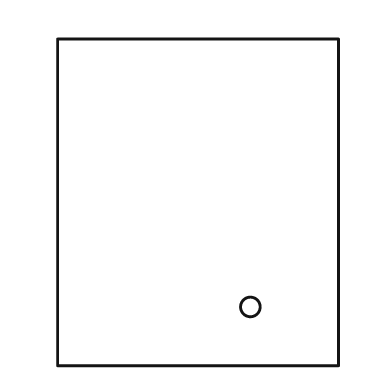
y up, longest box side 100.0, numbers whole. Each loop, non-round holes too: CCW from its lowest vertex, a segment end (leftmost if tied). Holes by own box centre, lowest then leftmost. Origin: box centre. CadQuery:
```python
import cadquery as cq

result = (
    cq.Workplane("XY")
    .moveTo(-43.0, -50.0)
    .lineTo(43.0, -50.0)
    .lineTo(43.0, 50.0)
    .lineTo(-43.0, 50.0)
    .close()
    .moveTo(16.0, -32.0)
    .circle(3.0)
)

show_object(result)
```